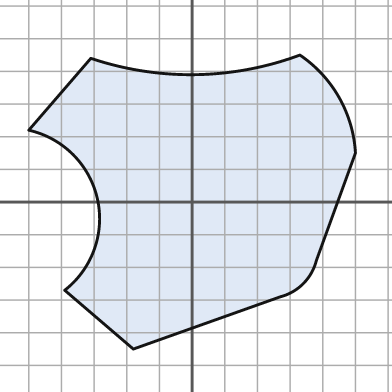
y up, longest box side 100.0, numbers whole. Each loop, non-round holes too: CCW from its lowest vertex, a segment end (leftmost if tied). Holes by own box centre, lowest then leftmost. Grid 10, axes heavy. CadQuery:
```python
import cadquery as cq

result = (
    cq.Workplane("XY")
    .moveTo(-18.0, -45.0)
    .lineTo(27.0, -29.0)
    .threePointArc((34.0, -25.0), (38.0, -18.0))
    .lineTo(50.0, 15.0)
    .threePointArc((45.0, 32.0), (33.0, 45.0))
    .threePointArc((1.0, 39.0), (-31.0, 44.0))
    .lineTo(-50.0, 22.0)
    .threePointArc((-29.0, 1.0), (-39.0, -27.0))
    .close()
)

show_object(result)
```